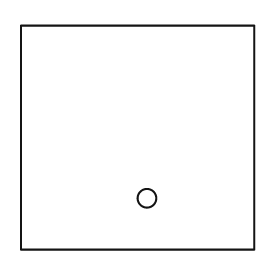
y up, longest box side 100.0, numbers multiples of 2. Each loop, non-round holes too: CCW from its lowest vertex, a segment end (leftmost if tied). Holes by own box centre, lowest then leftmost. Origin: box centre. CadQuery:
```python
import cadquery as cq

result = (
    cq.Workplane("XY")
    .moveTo(-50.0, -48.0)
    .lineTo(50.0, -48.0)
    .lineTo(50.0, 48.0)
    .lineTo(-50.0, 48.0)
    .close()
    .moveTo(4.0, -26.0)
    .circle(4.0)
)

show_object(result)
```